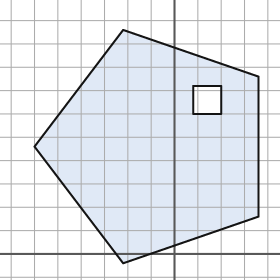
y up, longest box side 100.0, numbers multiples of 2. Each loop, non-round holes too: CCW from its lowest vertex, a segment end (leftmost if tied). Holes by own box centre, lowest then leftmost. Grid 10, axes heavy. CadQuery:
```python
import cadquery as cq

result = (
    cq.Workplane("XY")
    .moveTo(-22.0, -4.0)
    .lineTo(36.0, 16.0)
    .lineTo(36.0, 76.0)
    .lineTo(-22.0, 96.0)
    .lineTo(-60.0, 46.0)
    .close()
    .moveTo(8.0, 60.0)
    .lineTo(20.0, 60.0)
    .lineTo(20.0, 72.0)
    .lineTo(8.0, 72.0)
    .close()
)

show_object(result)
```